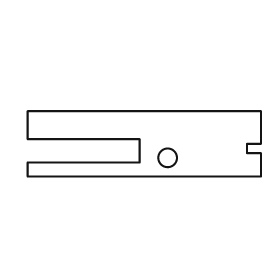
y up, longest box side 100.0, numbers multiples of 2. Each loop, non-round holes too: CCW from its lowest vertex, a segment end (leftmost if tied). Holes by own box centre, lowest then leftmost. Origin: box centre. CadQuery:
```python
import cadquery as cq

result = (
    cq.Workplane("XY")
    .moveTo(-50.0, -14.0)
    .lineTo(50.0, -14.0)
    .lineTo(50.0, -4.0)
    .lineTo(44.0, -4.0)
    .lineTo(44.0, 0.0)
    .lineTo(50.0, 0.0)
    .lineTo(50.0, 14.0)
    .lineTo(-50.0, 14.0)
    .lineTo(-50.0, 2.0)
    .lineTo(-2.0, 2.0)
    .lineTo(-2.0, -8.0)
    .lineTo(-50.0, -8.0)
    .close()
    .moveTo(10.0, -6.0)
    .circle(4.0)
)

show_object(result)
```